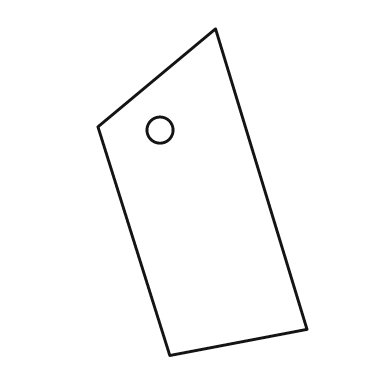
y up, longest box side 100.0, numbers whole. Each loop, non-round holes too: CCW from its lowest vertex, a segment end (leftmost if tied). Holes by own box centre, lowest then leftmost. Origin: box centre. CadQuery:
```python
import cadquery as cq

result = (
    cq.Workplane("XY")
    .moveTo(-10.0, -50.0)
    .lineTo(32.0, -42.0)
    .lineTo(4.0, 50.0)
    .lineTo(-32.0, 20.0)
    .close()
    .moveTo(-13.0, 19.0)
    .circle(4.0)
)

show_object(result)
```